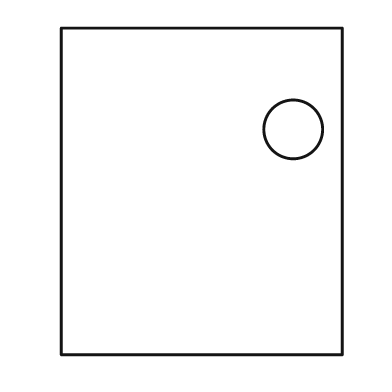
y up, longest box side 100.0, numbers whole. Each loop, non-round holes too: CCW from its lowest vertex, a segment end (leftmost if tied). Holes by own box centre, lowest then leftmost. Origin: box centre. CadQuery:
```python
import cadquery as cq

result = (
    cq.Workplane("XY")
    .moveTo(-43.0, -50.0)
    .lineTo(43.0, -50.0)
    .lineTo(43.0, 50.0)
    .lineTo(-43.0, 50.0)
    .close()
    .moveTo(28.0, 19.0)
    .circle(9.0)
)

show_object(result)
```